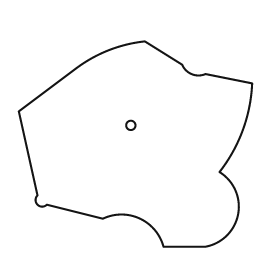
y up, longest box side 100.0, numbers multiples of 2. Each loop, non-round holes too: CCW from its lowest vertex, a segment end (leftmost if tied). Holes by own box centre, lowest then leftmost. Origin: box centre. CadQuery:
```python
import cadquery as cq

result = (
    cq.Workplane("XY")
    .moveTo(12.0, -44.0)
    .lineTo(30.0, -44.0)
    .threePointArc((44.0, -30.0), (36.0, -12.0))
    .threePointArc((46.0, 6.0), (50.0, 26.0))
    .lineTo(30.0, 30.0)
    .threePointArc((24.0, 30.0), (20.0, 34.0))
    .lineTo(4.0, 44.0)
    .threePointArc((-12.0, 40.0), (-26.0, 32.0))
    .lineTo(-50.0, 14.0)
    .lineTo(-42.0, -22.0)
    .threePointArc((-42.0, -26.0), (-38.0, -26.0))
    .lineTo(-14.0, -32.0)
    .threePointArc((2.0, -32.0), (12.0, -44.0))
    .close()
    .moveTo(-2.0, 8.0)
    .circle(2.0)
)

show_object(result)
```